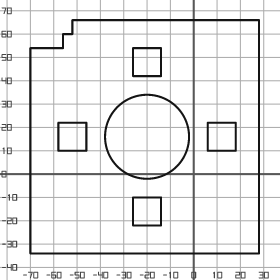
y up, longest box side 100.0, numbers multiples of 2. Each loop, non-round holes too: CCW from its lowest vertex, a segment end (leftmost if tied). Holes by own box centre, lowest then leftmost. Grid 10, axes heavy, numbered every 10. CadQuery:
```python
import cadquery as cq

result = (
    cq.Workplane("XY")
    .moveTo(-70.0, -34.0)
    .lineTo(28.0, -34.0)
    .lineTo(28.0, 66.0)
    .lineTo(-52.0, 66.0)
    .lineTo(-52.0, 60.0)
    .lineTo(-56.0, 60.0)
    .lineTo(-56.0, 54.0)
    .lineTo(-70.0, 54.0)
    .close()
    .moveTo(-26.0, -22.0)
    .lineTo(-14.0, -22.0)
    .lineTo(-14.0, -10.0)
    .lineTo(-26.0, -10.0)
    .close()
    .moveTo(-58.0, 10.0)
    .lineTo(-46.0, 10.0)
    .lineTo(-46.0, 22.0)
    .lineTo(-58.0, 22.0)
    .close()
    .moveTo(-20.0, 16.0)
    .circle(18.0)
    .moveTo(6.0, 10.0)
    .lineTo(18.0, 10.0)
    .lineTo(18.0, 22.0)
    .lineTo(6.0, 22.0)
    .close()
    .moveTo(-26.0, 42.0)
    .lineTo(-14.0, 42.0)
    .lineTo(-14.0, 54.0)
    .lineTo(-26.0, 54.0)
    .close()
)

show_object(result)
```